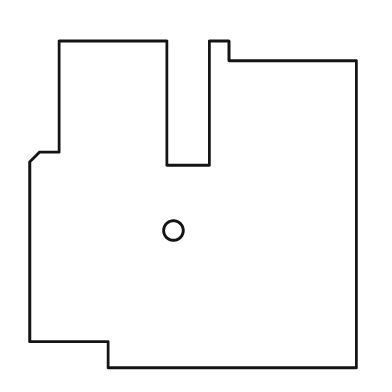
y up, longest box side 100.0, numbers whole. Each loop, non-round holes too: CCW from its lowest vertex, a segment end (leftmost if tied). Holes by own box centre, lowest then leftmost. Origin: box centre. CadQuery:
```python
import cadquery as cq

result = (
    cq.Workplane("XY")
    .moveTo(-26.0, -50.0)
    .lineTo(50.0, -50.0)
    .lineTo(50.0, 44.0)
    .lineTo(11.0, 44.0)
    .lineTo(11.0, 50.0)
    .lineTo(5.0, 50.0)
    .lineTo(5.0, 12.0)
    .lineTo(-8.0, 12.0)
    .lineTo(-8.0, 50.0)
    .lineTo(-41.0, 50.0)
    .lineTo(-41.0, 16.0)
    .lineTo(-47.0, 16.0)
    .lineTo(-50.0, 13.0)
    .lineTo(-50.0, -42.0)
    .lineTo(-26.0, -42.0)
    .close()
    .moveTo(-6.0, -8.0)
    .circle(3.0)
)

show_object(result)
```